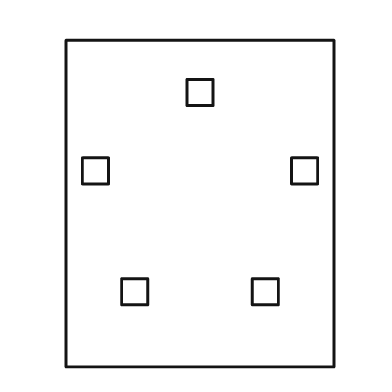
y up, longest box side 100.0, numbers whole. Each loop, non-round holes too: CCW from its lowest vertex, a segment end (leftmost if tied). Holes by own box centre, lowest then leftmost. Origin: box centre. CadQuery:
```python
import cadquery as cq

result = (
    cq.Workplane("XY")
    .moveTo(-41.0, -50.0)
    .lineTo(41.0, -50.0)
    .lineTo(41.0, 50.0)
    .lineTo(-41.0, 50.0)
    .close()
    .moveTo(-24.0, -31.0)
    .lineTo(-16.0, -31.0)
    .lineTo(-16.0, -23.0)
    .lineTo(-24.0, -23.0)
    .close()
    .moveTo(16.0, -31.0)
    .lineTo(24.0, -31.0)
    .lineTo(24.0, -23.0)
    .lineTo(16.0, -23.0)
    .close()
    .moveTo(-36.0, 6.0)
    .lineTo(-28.0, 6.0)
    .lineTo(-28.0, 14.0)
    .lineTo(-36.0, 14.0)
    .close()
    .moveTo(28.0, 6.0)
    .lineTo(36.0, 6.0)
    .lineTo(36.0, 14.0)
    .lineTo(28.0, 14.0)
    .close()
    .moveTo(-4.0, 30.0)
    .lineTo(4.0, 30.0)
    .lineTo(4.0, 38.0)
    .lineTo(-4.0, 38.0)
    .close()
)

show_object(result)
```